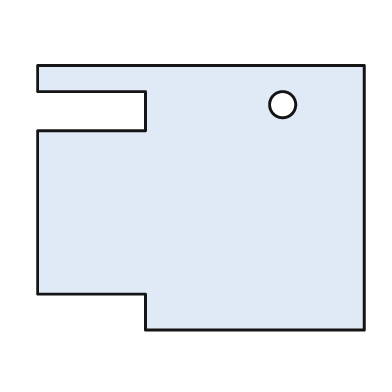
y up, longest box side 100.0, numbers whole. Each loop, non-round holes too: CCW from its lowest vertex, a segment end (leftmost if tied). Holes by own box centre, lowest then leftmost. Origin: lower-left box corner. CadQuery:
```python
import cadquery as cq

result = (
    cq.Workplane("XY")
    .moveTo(33.0, 0.0)
    .lineTo(100.0, 0.0)
    .lineTo(100.0, 81.0)
    .lineTo(0.0, 81.0)
    .lineTo(0.0, 73.0)
    .lineTo(33.0, 73.0)
    .lineTo(33.0, 61.0)
    .lineTo(0.0, 61.0)
    .lineTo(0.0, 11.0)
    .lineTo(33.0, 11.0)
    .close()
    .moveTo(75.0, 69.0)
    .circle(4.0)
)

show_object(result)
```